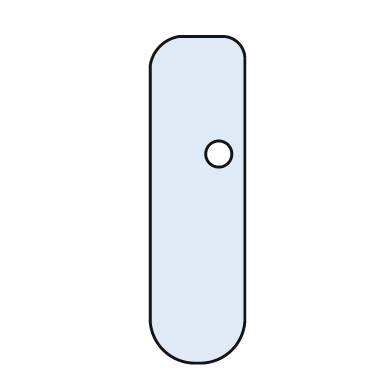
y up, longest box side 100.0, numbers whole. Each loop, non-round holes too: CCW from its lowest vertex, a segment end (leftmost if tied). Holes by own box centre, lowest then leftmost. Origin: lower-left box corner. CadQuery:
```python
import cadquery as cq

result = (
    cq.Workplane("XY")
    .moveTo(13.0, 0.0)
    .lineTo(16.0, 0.0)
    .threePointArc((25.0, 4.0), (29.0, 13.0))
    .lineTo(29.0, 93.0)
    .threePointArc((27.0, 98.0), (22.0, 100.0))
    .lineTo(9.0, 100.0)
    .threePointArc((3.0, 97.0), (0.0, 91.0))
    .lineTo(0.0, 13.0)
    .threePointArc((4.0, 4.0), (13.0, 0.0))
    .close()
    .moveTo(21.0, 64.0)
    .circle(4.0)
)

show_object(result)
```